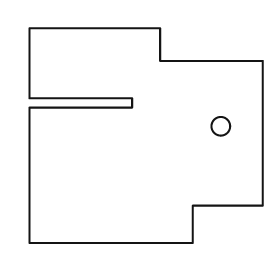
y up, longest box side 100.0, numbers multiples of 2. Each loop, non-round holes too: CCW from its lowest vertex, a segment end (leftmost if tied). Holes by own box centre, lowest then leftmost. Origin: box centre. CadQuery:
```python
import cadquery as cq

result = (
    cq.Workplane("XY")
    .moveTo(-50.0, -46.0)
    .lineTo(20.0, -46.0)
    .lineTo(20.0, -30.0)
    .lineTo(50.0, -30.0)
    .lineTo(50.0, 32.0)
    .lineTo(6.0, 32.0)
    .lineTo(6.0, 46.0)
    .lineTo(-50.0, 46.0)
    .lineTo(-50.0, 16.0)
    .lineTo(-6.0, 16.0)
    .lineTo(-6.0, 12.0)
    .lineTo(-50.0, 12.0)
    .close()
    .moveTo(32.0, 4.0)
    .circle(4.0)
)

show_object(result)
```